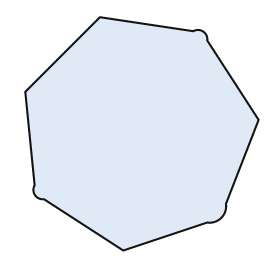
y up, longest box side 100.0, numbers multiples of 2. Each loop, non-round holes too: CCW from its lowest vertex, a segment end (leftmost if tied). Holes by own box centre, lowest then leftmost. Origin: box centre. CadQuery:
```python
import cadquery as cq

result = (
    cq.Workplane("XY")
    .moveTo(-8.0, -50.0)
    .lineTo(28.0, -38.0)
    .threePointArc((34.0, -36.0), (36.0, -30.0))
    .lineTo(50.0, 6.0)
    .lineTo(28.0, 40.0)
    .threePointArc((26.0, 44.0), (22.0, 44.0))
    .lineTo(-18.0, 50.0)
    .lineTo(-50.0, 18.0)
    .lineTo(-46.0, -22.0)
    .threePointArc((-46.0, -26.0), (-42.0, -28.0))
    .close()
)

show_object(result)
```